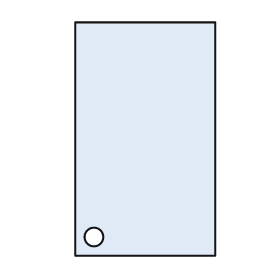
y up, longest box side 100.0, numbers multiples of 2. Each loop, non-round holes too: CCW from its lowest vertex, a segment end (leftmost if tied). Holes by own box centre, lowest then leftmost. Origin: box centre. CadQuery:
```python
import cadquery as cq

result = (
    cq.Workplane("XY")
    .moveTo(-30.0, -50.0)
    .lineTo(30.0, -50.0)
    .lineTo(30.0, 50.0)
    .lineTo(-30.0, 50.0)
    .close()
    .moveTo(-22.0, -42.0)
    .circle(4.0)
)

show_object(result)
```